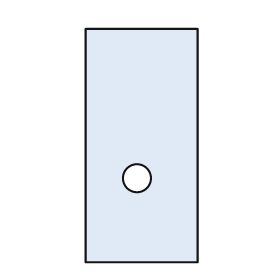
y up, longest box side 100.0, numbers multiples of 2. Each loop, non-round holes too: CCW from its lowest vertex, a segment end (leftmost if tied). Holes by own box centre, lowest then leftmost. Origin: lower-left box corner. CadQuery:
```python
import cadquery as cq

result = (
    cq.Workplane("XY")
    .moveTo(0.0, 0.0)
    .lineTo(48.0, 0.0)
    .lineTo(48.0, 100.0)
    .lineTo(0.0, 100.0)
    .close()
    .moveTo(22.0, 36.0)
    .circle(6.0)
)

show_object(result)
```